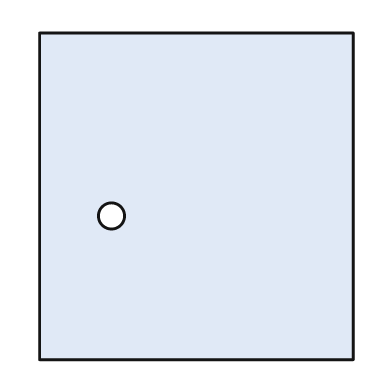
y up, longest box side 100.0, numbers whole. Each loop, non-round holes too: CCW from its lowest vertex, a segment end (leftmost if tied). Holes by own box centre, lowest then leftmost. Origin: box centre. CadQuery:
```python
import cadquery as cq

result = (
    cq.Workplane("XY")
    .moveTo(-48.0, -50.0)
    .lineTo(48.0, -50.0)
    .lineTo(48.0, 50.0)
    .lineTo(-48.0, 50.0)
    .close()
    .moveTo(-26.0, -6.0)
    .circle(4.0)
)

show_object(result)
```